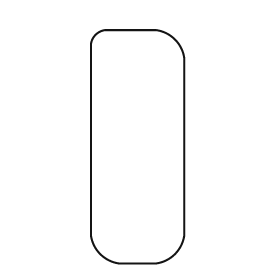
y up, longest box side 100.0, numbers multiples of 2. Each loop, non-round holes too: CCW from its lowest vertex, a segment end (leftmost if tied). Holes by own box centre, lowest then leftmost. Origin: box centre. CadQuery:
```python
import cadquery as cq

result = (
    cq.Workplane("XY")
    .moveTo(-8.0, -50.0)
    .lineTo(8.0, -50.0)
    .threePointArc((16.0, -46.0), (20.0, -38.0))
    .lineTo(20.0, 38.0)
    .threePointArc((16.0, 46.0), (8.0, 50.0))
    .lineTo(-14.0, 50.0)
    .threePointArc((-18.0, 48.0), (-20.0, 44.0))
    .lineTo(-20.0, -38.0)
    .threePointArc((-16.0, -46.0), (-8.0, -50.0))
    .close()
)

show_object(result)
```